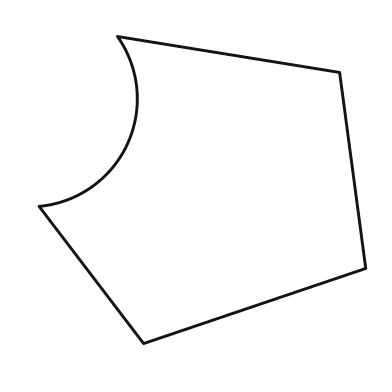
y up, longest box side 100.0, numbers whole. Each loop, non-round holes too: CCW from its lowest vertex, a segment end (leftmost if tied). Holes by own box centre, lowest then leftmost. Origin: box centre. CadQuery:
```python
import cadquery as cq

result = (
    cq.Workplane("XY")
    .moveTo(-18.0, -47.0)
    .lineTo(50.0, -24.0)
    .lineTo(42.0, 36.0)
    .lineTo(-26.0, 47.0)
    .threePointArc((-23.0, 14.0), (-50.0, -5.0))
    .close()
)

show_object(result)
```